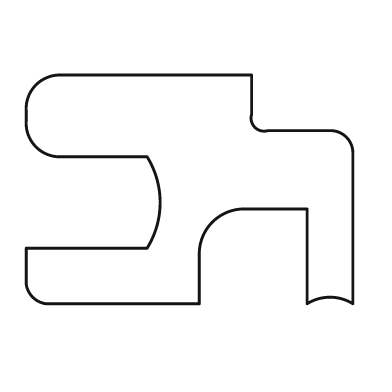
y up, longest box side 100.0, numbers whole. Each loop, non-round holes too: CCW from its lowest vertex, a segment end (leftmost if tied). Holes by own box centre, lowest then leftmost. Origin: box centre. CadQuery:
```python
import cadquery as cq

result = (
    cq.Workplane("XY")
    .moveTo(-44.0, -35.0)
    .lineTo(3.0, -35.0)
    .lineTo(3.0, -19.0)
    .threePointArc((7.0, -10.0), (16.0, -6.0))
    .lineTo(36.0, -6.0)
    .lineTo(36.0, -35.0)
    .threePointArc((43.0, -33.0), (50.0, -35.0))
    .lineTo(50.0, 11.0)
    .threePointArc((48.0, 16.0), (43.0, 18.0))
    .lineTo(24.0, 18.0)
    .threePointArc((20.0, 19.0), (19.0, 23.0))
    .lineTo(19.0, 35.0)
    .lineTo(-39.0, 35.0)
    .threePointArc((-47.0, 32.0), (-50.0, 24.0))
    .lineTo(-50.0, 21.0)
    .threePointArc((-47.0, 13.0), (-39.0, 10.0))
    .lineTo(-13.0, 10.0)
    .threePointArc((-9.0, -4.0), (-13.0, -18.0))
    .lineTo(-50.0, -18.0)
    .lineTo(-50.0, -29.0)
    .threePointArc((-48.0, -33.0), (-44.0, -35.0))
    .close()
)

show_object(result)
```